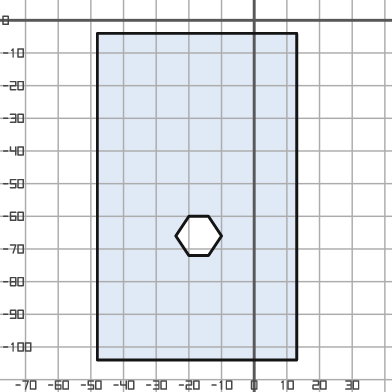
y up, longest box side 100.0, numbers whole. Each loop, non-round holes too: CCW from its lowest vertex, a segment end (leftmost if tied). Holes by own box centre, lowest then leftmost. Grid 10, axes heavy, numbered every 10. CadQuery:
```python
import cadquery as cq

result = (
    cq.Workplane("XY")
    .moveTo(-48.0, -104.0)
    .lineTo(13.0, -104.0)
    .lineTo(13.0, -4.0)
    .lineTo(-48.0, -4.0)
    .close()
    .moveTo(-20.0, -72.0)
    .lineTo(-14.0, -72.0)
    .lineTo(-10.0, -66.0)
    .lineTo(-14.0, -60.0)
    .lineTo(-20.0, -60.0)
    .lineTo(-24.0, -66.0)
    .close()
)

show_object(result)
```